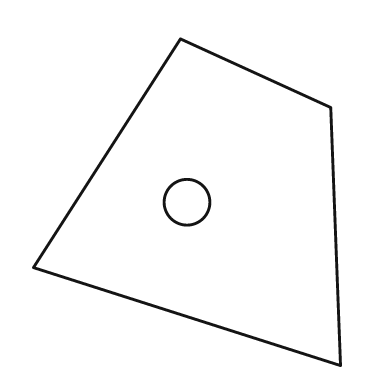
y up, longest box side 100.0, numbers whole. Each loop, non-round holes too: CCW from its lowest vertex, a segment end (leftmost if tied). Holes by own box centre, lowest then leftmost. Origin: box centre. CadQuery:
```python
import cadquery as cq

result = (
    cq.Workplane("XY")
    .moveTo(47.0, -50.0)
    .lineTo(44.0, 29.0)
    .lineTo(-2.0, 50.0)
    .lineTo(-47.0, -20.0)
    .close()
    .moveTo(0.0, 0.0)
    .circle(7.0)
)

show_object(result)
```